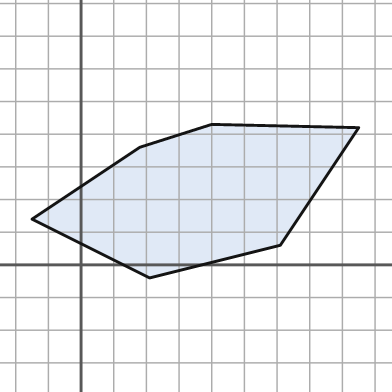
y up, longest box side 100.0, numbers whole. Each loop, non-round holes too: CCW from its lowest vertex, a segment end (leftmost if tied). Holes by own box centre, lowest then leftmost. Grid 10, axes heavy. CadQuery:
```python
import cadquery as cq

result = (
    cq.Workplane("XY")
    .moveTo(21.0, -4.0)
    .lineTo(61.0, 6.0)
    .lineTo(85.0, 42.0)
    .lineTo(40.0, 43.0)
    .lineTo(18.0, 36.0)
    .lineTo(-15.0, 14.0)
    .close()
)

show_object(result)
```